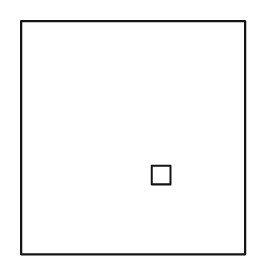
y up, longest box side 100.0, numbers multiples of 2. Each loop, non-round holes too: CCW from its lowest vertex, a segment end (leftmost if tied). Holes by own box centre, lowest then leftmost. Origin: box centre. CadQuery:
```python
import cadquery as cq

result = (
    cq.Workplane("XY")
    .moveTo(-48.0, -50.0)
    .lineTo(48.0, -50.0)
    .lineTo(48.0, 50.0)
    .lineTo(-48.0, 50.0)
    .close()
    .moveTo(8.0, -20.0)
    .lineTo(16.0, -20.0)
    .lineTo(16.0, -12.0)
    .lineTo(8.0, -12.0)
    .close()
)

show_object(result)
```